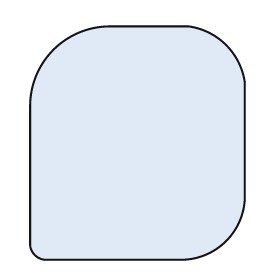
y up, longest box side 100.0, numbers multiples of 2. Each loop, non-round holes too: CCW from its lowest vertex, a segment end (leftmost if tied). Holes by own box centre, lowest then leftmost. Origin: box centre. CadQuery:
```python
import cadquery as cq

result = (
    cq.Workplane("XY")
    .moveTo(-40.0, -50.0)
    .lineTo(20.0, -50.0)
    .threePointArc((38.0, -42.0), (46.0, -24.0))
    .lineTo(46.0, 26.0)
    .threePointArc((38.0, 42.0), (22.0, 50.0))
    .lineTo(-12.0, 50.0)
    .threePointArc((-36.0, 40.0), (-46.0, 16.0))
    .lineTo(-46.0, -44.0)
    .threePointArc((-44.0, -48.0), (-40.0, -50.0))
    .close()
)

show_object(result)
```